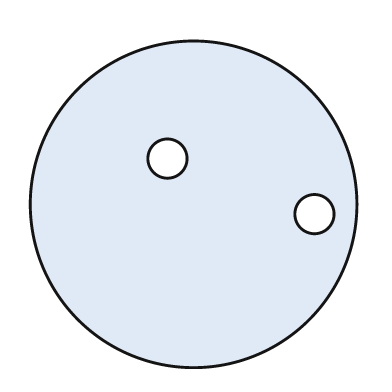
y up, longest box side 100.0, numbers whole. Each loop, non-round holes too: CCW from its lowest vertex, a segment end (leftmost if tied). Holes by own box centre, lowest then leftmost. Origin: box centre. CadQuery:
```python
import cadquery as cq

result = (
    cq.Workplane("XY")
    .moveTo(0.0, 0.0)
    .circle(50.0)
    .moveTo(37.0, -3.0)
    .circle(6.0)
    .moveTo(-8.0, 14.0)
    .circle(6.0)
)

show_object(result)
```